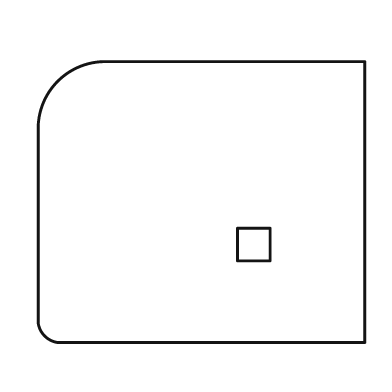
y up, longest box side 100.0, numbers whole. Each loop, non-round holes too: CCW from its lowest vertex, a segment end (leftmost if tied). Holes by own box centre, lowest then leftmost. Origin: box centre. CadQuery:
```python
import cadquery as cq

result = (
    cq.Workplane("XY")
    .moveTo(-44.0, -43.0)
    .lineTo(50.0, -43.0)
    .lineTo(50.0, 43.0)
    .lineTo(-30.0, 43.0)
    .threePointArc((-44.0, 37.0), (-50.0, 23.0))
    .lineTo(-50.0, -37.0)
    .threePointArc((-48.0, -41.0), (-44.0, -43.0))
    .close()
    .moveTo(11.0, -18.0)
    .lineTo(21.0, -18.0)
    .lineTo(21.0, -8.0)
    .lineTo(11.0, -8.0)
    .close()
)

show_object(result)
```